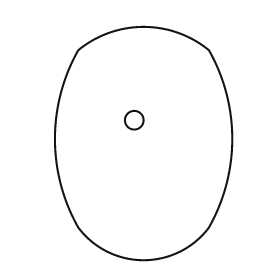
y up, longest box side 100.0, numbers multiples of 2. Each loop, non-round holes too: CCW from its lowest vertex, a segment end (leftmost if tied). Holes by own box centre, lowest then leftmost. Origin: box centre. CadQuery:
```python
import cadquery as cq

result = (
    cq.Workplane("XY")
    .moveTo(-28.0, -36.0)
    .threePointArc((0.0, -50.0), (28.0, -36.0))
    .threePointArc((38.0, 2.0), (28.0, 40.0))
    .threePointArc((0.0, 50.0), (-28.0, 40.0))
    .threePointArc((-38.0, 2.0), (-28.0, -36.0))
    .close()
    .moveTo(-4.0, 10.0)
    .circle(4.0)
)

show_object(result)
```